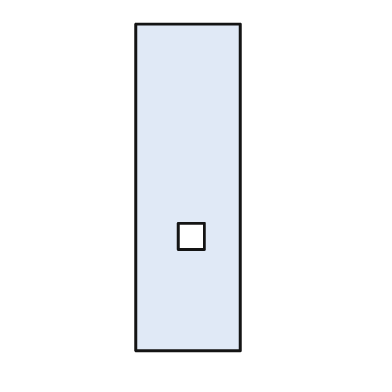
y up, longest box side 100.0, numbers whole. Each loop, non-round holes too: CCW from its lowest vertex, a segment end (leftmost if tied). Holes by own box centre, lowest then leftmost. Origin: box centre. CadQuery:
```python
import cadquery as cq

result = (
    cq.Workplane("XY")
    .moveTo(-16.0, -50.0)
    .lineTo(16.0, -50.0)
    .lineTo(16.0, 50.0)
    .lineTo(-16.0, 50.0)
    .close()
    .moveTo(-3.0, -19.0)
    .lineTo(5.0, -19.0)
    .lineTo(5.0, -11.0)
    .lineTo(-3.0, -11.0)
    .close()
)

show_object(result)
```